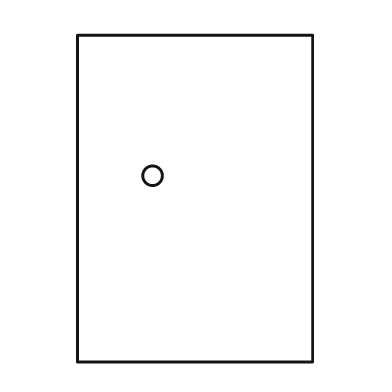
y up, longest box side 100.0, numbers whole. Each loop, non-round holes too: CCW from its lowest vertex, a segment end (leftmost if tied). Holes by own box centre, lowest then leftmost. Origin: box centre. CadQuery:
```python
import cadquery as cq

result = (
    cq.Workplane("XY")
    .moveTo(-36.0, -50.0)
    .lineTo(36.0, -50.0)
    .lineTo(36.0, 50.0)
    .lineTo(-36.0, 50.0)
    .close()
    .moveTo(-13.0, 7.0)
    .circle(3.0)
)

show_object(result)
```